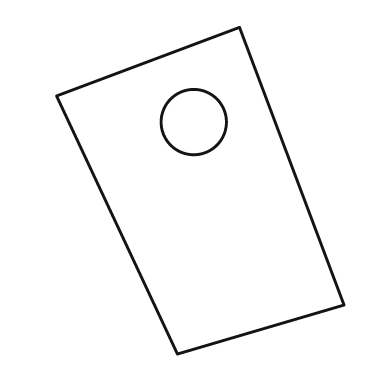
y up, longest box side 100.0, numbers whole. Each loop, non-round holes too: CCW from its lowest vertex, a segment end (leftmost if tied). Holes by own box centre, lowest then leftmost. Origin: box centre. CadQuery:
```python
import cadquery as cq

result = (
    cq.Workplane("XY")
    .moveTo(-7.0, -50.0)
    .lineTo(44.0, -35.0)
    .lineTo(12.0, 50.0)
    .lineTo(-44.0, 29.0)
    .close()
    .moveTo(-2.0, 21.0)
    .circle(10.0)
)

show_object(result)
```